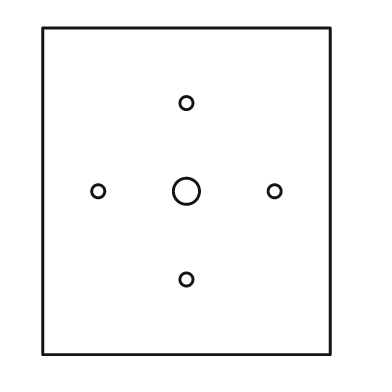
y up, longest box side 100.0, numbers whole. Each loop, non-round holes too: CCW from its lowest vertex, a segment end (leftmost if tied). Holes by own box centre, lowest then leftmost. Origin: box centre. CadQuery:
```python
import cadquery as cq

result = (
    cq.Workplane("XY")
    .moveTo(-44.0, -50.0)
    .lineTo(44.0, -50.0)
    .lineTo(44.0, 50.0)
    .lineTo(-44.0, 50.0)
    .close()
    .moveTo(0.0, -27.0)
    .circle(2.0)
    .moveTo(-27.0, 0.0)
    .circle(2.0)
    .moveTo(0.0, 0.0)
    .circle(4.0)
    .moveTo(27.0, 0.0)
    .circle(2.0)
    .moveTo(0.0, 27.0)
    .circle(2.0)
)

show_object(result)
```